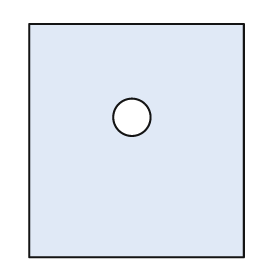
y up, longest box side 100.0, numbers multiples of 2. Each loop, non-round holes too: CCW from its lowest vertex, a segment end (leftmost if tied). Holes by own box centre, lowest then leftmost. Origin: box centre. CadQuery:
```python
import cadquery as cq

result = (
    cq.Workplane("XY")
    .moveTo(-46.0, -50.0)
    .lineTo(46.0, -50.0)
    .lineTo(46.0, 50.0)
    .lineTo(-46.0, 50.0)
    .close()
    .moveTo(-2.0, 10.0)
    .circle(8.0)
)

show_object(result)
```